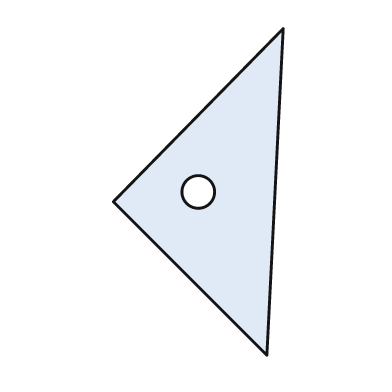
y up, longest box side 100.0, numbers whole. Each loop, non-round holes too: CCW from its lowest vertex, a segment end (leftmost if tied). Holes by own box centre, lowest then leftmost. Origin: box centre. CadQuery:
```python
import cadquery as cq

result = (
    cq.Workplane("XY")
    .moveTo(21.0, -50.0)
    .lineTo(26.0, 50.0)
    .lineTo(-26.0, -3.0)
    .close()
    .moveTo(0.0, 0.0)
    .circle(5.0)
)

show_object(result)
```